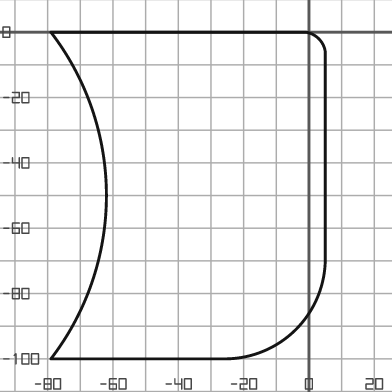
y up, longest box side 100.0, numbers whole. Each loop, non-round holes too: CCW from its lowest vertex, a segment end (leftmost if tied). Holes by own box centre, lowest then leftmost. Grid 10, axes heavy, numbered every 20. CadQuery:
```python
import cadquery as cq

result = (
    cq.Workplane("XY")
    .moveTo(-79.0, -100.0)
    .lineTo(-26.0, -100.0)
    .threePointArc((-4.0, -91.0), (5.0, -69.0))
    .lineTo(5.0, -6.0)
    .threePointArc((3.0, -2.0), (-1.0, 0.0))
    .lineTo(-79.0, 0.0)
    .threePointArc((-62.0, -50.0), (-79.0, -100.0))
    .close()
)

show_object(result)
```